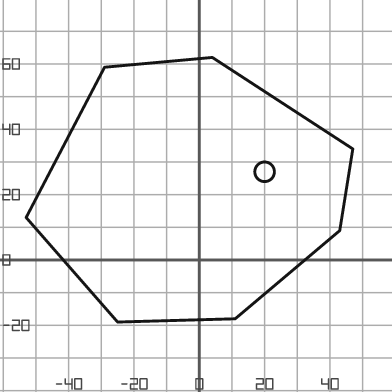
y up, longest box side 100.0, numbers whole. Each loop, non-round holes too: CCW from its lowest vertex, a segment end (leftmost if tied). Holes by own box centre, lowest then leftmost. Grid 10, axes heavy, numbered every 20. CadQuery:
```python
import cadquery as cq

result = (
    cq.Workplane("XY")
    .moveTo(-25.0, -19.0)
    .lineTo(11.0, -18.0)
    .lineTo(43.0, 9.0)
    .lineTo(47.0, 34.0)
    .lineTo(4.0, 62.0)
    .lineTo(-29.0, 59.0)
    .lineTo(-53.0, 13.0)
    .close()
    .moveTo(20.0, 27.0)
    .circle(3.0)
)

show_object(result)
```